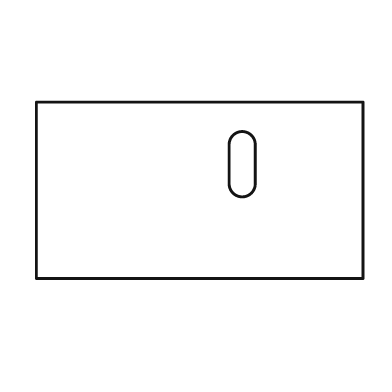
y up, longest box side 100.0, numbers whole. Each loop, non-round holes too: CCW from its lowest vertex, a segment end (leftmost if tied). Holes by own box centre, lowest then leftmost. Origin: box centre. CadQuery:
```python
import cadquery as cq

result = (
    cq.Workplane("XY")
    .moveTo(-50.0, -27.0)
    .lineTo(50.0, -27.0)
    .lineTo(50.0, 27.0)
    .lineTo(-50.0, 27.0)
    .close()
    .moveTo(9.0, 2.0)
    .threePointArc((13.0, -2.0), (17.0, 2.0))
    .lineTo(17.0, 14.0)
    .threePointArc((13.0, 18.0), (9.0, 14.0))
    .close()
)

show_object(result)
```